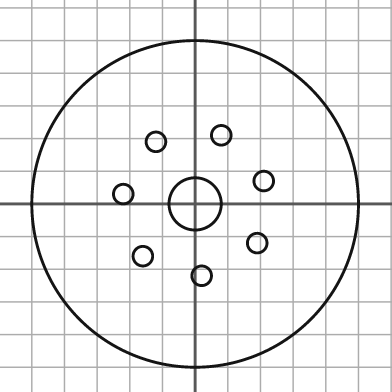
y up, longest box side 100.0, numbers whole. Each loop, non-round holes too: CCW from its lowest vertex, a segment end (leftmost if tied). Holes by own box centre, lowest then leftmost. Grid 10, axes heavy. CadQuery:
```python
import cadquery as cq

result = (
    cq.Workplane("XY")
    .moveTo(0.0, 0.0)
    .circle(50.0)
    .moveTo(2.0, -22.0)
    .circle(3.0)
    .moveTo(-16.0, -16.0)
    .circle(3.0)
    .moveTo(19.0, -12.0)
    .circle(3.0)
    .moveTo(0.0, 0.0)
    .circle(8.0)
    .moveTo(-22.0, 3.0)
    .circle(3.0)
    .moveTo(21.0, 7.0)
    .circle(3.0)
    .moveTo(-12.0, 19.0)
    .circle(3.0)
    .moveTo(8.0, 21.0)
    .circle(3.0)
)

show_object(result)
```